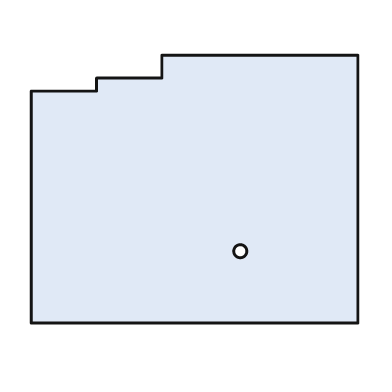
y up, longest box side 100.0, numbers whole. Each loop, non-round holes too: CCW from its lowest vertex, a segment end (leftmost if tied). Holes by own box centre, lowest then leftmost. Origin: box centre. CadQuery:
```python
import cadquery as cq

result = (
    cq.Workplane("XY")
    .moveTo(-50.0, -41.0)
    .lineTo(50.0, -41.0)
    .lineTo(50.0, 41.0)
    .lineTo(-10.0, 41.0)
    .lineTo(-10.0, 34.0)
    .lineTo(-30.0, 34.0)
    .lineTo(-30.0, 30.0)
    .lineTo(-50.0, 30.0)
    .close()
    .moveTo(14.0, -19.0)
    .circle(2.0)
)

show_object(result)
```